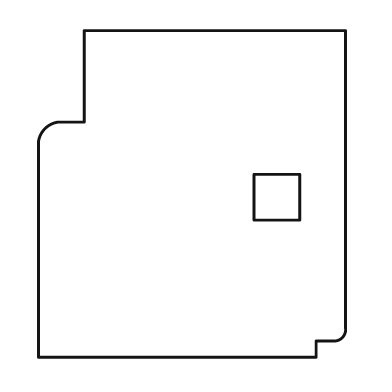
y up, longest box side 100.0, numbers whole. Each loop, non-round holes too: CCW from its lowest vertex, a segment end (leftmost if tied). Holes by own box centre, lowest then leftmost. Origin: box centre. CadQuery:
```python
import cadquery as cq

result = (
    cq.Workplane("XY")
    .moveTo(-47.0, -50.0)
    .lineTo(38.0, -50.0)
    .lineTo(38.0, -45.0)
    .lineTo(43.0, -45.0)
    .threePointArc((46.0, -44.0), (47.0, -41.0))
    .lineTo(47.0, 50.0)
    .lineTo(-33.0, 50.0)
    .lineTo(-33.0, 22.0)
    .lineTo(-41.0, 22.0)
    .threePointArc((-45.0, 20.0), (-47.0, 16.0))
    .close()
    .moveTo(19.0, -8.0)
    .lineTo(33.0, -8.0)
    .lineTo(33.0, 6.0)
    .lineTo(19.0, 6.0)
    .close()
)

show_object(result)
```